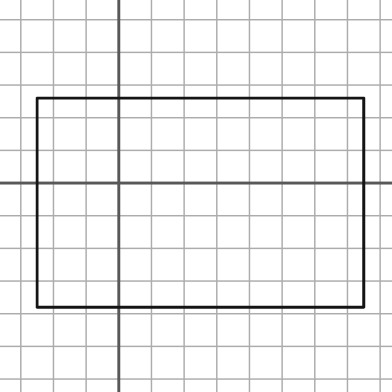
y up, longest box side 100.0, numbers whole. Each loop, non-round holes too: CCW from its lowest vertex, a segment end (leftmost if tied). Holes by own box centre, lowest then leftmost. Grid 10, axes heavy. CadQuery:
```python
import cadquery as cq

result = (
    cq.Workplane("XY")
    .moveTo(-25.0, -38.0)
    .lineTo(75.0, -38.0)
    .lineTo(75.0, 26.0)
    .lineTo(-25.0, 26.0)
    .close()
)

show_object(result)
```